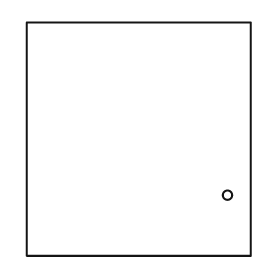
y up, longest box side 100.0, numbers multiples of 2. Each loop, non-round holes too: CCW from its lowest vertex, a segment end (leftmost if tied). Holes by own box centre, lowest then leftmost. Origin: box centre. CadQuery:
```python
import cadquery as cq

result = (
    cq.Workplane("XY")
    .moveTo(-48.0, -50.0)
    .lineTo(48.0, -50.0)
    .lineTo(48.0, 50.0)
    .lineTo(-48.0, 50.0)
    .close()
    .moveTo(38.0, -24.0)
    .circle(2.0)
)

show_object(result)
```